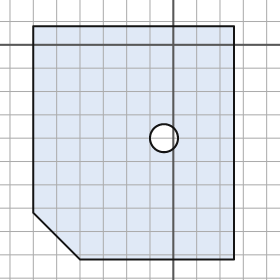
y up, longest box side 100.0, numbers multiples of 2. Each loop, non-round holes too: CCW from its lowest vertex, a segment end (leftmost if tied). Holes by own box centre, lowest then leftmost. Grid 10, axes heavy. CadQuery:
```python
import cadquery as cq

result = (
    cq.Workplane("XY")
    .moveTo(-40.0, -92.0)
    .lineTo(26.0, -92.0)
    .lineTo(26.0, 8.0)
    .lineTo(-60.0, 8.0)
    .lineTo(-60.0, -72.0)
    .close()
    .moveTo(-4.0, -40.0)
    .circle(6.0)
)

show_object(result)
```